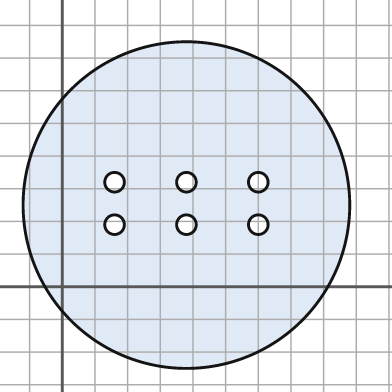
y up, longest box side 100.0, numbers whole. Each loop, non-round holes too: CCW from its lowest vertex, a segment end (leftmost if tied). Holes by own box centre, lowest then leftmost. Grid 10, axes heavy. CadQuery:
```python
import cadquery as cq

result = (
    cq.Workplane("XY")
    .moveTo(38.0, 25.0)
    .circle(50.0)
    .moveTo(16.0, 19.0)
    .circle(3.0)
    .moveTo(38.0, 19.0)
    .circle(3.0)
    .moveTo(60.0, 19.0)
    .circle(3.0)
    .moveTo(16.0, 32.0)
    .circle(3.0)
    .moveTo(38.0, 32.0)
    .circle(3.0)
    .moveTo(60.0, 32.0)
    .circle(3.0)
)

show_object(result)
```